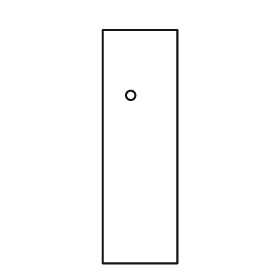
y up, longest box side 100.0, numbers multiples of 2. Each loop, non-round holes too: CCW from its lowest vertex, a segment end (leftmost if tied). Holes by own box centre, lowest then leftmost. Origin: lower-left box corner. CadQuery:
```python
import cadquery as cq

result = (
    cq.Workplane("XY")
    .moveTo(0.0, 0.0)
    .lineTo(32.0, 0.0)
    .lineTo(32.0, 100.0)
    .lineTo(0.0, 100.0)
    .close()
    .moveTo(12.0, 72.0)
    .circle(2.0)
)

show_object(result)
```